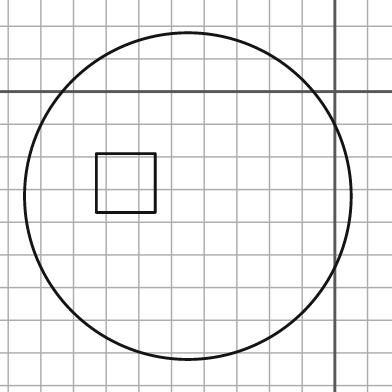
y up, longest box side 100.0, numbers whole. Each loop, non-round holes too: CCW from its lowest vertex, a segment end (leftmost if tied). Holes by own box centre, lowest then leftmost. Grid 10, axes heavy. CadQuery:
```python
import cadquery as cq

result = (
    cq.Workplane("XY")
    .moveTo(-45.0, -32.0)
    .circle(50.0)
    .moveTo(-73.0, -37.0)
    .lineTo(-55.0, -37.0)
    .lineTo(-55.0, -19.0)
    .lineTo(-73.0, -19.0)
    .close()
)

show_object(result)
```